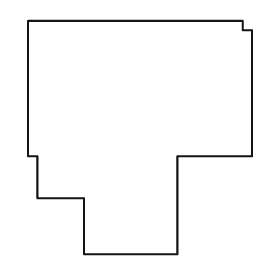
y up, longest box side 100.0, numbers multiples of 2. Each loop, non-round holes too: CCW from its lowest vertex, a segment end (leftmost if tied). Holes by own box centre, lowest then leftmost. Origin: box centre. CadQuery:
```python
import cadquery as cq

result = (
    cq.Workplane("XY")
    .moveTo(-24.0, -50.0)
    .lineTo(16.0, -50.0)
    .lineTo(16.0, -8.0)
    .lineTo(48.0, -8.0)
    .lineTo(48.0, 46.0)
    .lineTo(44.0, 46.0)
    .lineTo(44.0, 50.0)
    .lineTo(-48.0, 50.0)
    .lineTo(-48.0, -8.0)
    .lineTo(-44.0, -8.0)
    .lineTo(-44.0, -26.0)
    .lineTo(-24.0, -26.0)
    .close()
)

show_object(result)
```